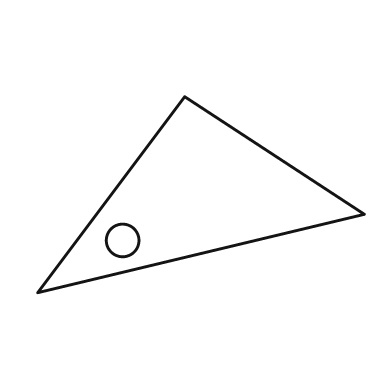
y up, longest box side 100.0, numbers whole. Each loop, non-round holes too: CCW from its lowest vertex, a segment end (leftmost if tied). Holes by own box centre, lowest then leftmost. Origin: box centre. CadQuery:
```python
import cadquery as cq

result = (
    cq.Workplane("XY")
    .moveTo(-50.0, -30.0)
    .lineTo(50.0, -6.0)
    .lineTo(-5.0, 30.0)
    .close()
    .moveTo(-24.0, -14.0)
    .circle(5.0)
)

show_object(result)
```